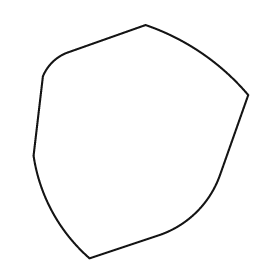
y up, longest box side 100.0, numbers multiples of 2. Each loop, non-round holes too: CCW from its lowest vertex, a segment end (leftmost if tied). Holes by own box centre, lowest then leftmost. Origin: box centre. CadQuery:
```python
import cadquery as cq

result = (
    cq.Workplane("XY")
    .moveTo(-22.0, -50.0)
    .lineTo(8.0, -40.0)
    .threePointArc((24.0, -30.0), (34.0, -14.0))
    .lineTo(46.0, 20.0)
    .threePointArc((26.0, 38.0), (2.0, 50.0))
    .lineTo(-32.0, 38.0)
    .threePointArc((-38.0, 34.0), (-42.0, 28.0))
    .lineTo(-46.0, -6.0)
    .threePointArc((-38.0, -30.0), (-22.0, -50.0))
    .close()
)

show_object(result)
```